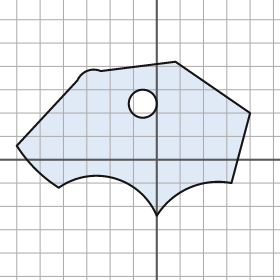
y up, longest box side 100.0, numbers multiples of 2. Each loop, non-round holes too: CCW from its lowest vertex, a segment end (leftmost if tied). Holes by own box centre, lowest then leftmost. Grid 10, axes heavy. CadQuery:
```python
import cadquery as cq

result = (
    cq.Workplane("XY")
    .moveTo(0.0, -24.0)
    .threePointArc((14.0, -12.0), (32.0, -10.0))
    .lineTo(40.0, 20.0)
    .lineTo(8.0, 42.0)
    .lineTo(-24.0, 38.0)
    .threePointArc((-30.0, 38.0), (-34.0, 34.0))
    .lineTo(-60.0, 6.0)
    .threePointArc((-52.0, -4.0), (-42.0, -12.0))
    .threePointArc((-18.0, -8.0), (0.0, -24.0))
    .close()
    .moveTo(-6.0, 24.0)
    .circle(6.0)
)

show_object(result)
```